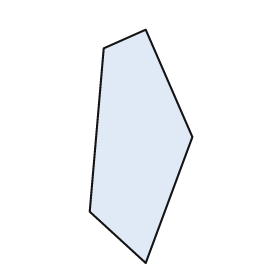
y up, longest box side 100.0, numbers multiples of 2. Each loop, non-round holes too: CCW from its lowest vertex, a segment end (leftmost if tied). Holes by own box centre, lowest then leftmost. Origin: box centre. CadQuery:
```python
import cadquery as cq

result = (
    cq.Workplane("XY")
    .moveTo(2.0, -50.0)
    .lineTo(22.0, 4.0)
    .lineTo(2.0, 50.0)
    .lineTo(-16.0, 42.0)
    .lineTo(-22.0, -28.0)
    .close()
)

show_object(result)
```